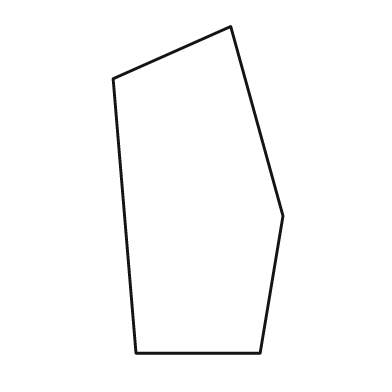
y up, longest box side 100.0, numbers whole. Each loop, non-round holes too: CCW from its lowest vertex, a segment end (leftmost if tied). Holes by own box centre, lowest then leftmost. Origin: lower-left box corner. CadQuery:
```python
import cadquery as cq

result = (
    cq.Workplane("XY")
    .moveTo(7.0, 0.0)
    .lineTo(45.0, 0.0)
    .lineTo(52.0, 42.0)
    .lineTo(36.0, 100.0)
    .lineTo(0.0, 84.0)
    .close()
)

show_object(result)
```